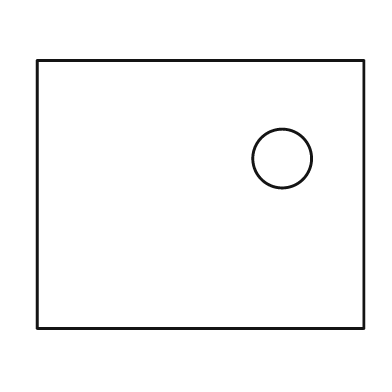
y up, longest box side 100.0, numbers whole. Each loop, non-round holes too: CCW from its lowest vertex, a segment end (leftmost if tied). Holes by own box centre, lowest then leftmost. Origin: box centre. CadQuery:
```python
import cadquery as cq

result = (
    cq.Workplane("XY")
    .moveTo(-50.0, -41.0)
    .lineTo(50.0, -41.0)
    .lineTo(50.0, 41.0)
    .lineTo(-50.0, 41.0)
    .close()
    .moveTo(25.0, 11.0)
    .circle(9.0)
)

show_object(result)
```